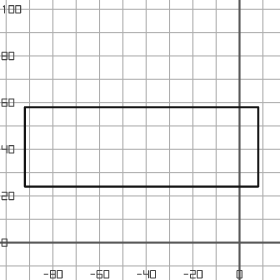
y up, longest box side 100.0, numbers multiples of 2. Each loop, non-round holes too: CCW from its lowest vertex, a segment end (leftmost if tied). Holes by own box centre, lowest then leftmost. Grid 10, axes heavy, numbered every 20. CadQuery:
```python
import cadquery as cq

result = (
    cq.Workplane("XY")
    .moveTo(-92.0, 24.0)
    .lineTo(8.0, 24.0)
    .lineTo(8.0, 58.0)
    .lineTo(-92.0, 58.0)
    .close()
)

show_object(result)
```